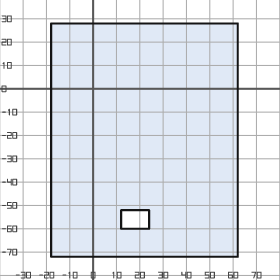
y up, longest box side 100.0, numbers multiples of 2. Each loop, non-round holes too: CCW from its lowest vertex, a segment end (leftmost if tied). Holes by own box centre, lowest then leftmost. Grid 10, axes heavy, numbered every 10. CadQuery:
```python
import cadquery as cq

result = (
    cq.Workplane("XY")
    .moveTo(-18.0, -72.0)
    .lineTo(62.0, -72.0)
    .lineTo(62.0, 28.0)
    .lineTo(-18.0, 28.0)
    .close()
    .moveTo(12.0, -60.0)
    .lineTo(24.0, -60.0)
    .lineTo(24.0, -52.0)
    .lineTo(12.0, -52.0)
    .close()
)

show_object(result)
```